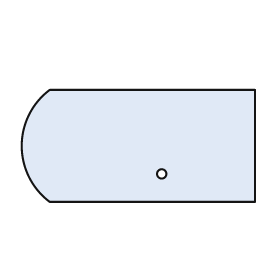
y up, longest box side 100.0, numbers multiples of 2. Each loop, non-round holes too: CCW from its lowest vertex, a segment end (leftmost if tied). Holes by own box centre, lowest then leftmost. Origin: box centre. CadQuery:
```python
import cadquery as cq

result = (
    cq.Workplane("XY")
    .moveTo(-38.0, -24.0)
    .lineTo(50.0, -24.0)
    .lineTo(50.0, 24.0)
    .lineTo(-38.0, 24.0)
    .threePointArc((-50.0, 0.0), (-38.0, -24.0))
    .close()
    .moveTo(10.0, -12.0)
    .circle(2.0)
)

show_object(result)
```